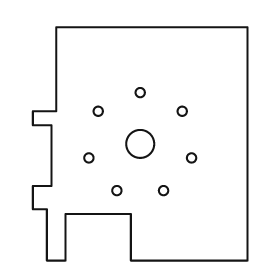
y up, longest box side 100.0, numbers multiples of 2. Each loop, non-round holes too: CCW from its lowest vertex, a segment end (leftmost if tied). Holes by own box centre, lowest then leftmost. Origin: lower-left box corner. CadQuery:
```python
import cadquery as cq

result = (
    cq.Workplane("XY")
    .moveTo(6.0, 0.0)
    .lineTo(14.0, 0.0)
    .lineTo(14.0, 20.0)
    .lineTo(42.0, 20.0)
    .lineTo(42.0, 0.0)
    .lineTo(92.0, 0.0)
    .lineTo(92.0, 100.0)
    .lineTo(10.0, 100.0)
    .lineTo(10.0, 64.0)
    .lineTo(0.0, 64.0)
    .lineTo(0.0, 58.0)
    .lineTo(8.0, 58.0)
    .lineTo(8.0, 32.0)
    .lineTo(0.0, 32.0)
    .lineTo(0.0, 22.0)
    .lineTo(6.0, 22.0)
    .close()
    .moveTo(36.0, 30.0)
    .circle(2.0)
    .moveTo(56.0, 30.0)
    .circle(2.0)
    .moveTo(24.0, 44.0)
    .circle(2.0)
    .moveTo(68.0, 44.0)
    .circle(2.0)
    .moveTo(46.0, 50.0)
    .circle(6.0)
    .moveTo(28.0, 64.0)
    .circle(2.0)
    .moveTo(64.0, 64.0)
    .circle(2.0)
    .moveTo(46.0, 72.0)
    .circle(2.0)
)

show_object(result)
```